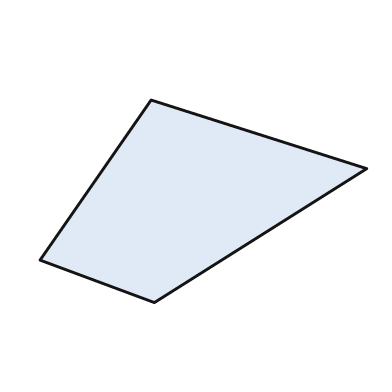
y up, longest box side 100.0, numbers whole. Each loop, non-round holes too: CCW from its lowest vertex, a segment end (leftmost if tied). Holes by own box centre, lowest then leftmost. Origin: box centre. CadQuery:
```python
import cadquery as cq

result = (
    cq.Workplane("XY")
    .moveTo(-15.0, -31.0)
    .lineTo(50.0, 10.0)
    .lineTo(-16.0, 31.0)
    .lineTo(-50.0, -18.0)
    .close()
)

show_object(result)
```